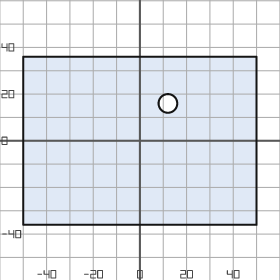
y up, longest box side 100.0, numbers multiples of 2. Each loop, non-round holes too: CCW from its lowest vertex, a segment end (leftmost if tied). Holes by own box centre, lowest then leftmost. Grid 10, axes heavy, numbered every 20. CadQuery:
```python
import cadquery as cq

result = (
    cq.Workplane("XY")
    .moveTo(-50.0, -36.0)
    .lineTo(50.0, -36.0)
    .lineTo(50.0, 36.0)
    .lineTo(-50.0, 36.0)
    .close()
    .moveTo(12.0, 16.0)
    .circle(4.0)
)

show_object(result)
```